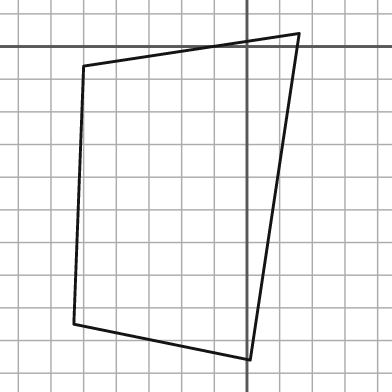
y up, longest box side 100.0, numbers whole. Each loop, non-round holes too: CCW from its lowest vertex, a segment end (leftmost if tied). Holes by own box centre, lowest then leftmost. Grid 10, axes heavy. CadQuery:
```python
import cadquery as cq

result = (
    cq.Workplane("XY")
    .moveTo(1.0, -96.0)
    .lineTo(16.0, 4.0)
    .lineTo(-50.0, -6.0)
    .lineTo(-53.0, -85.0)
    .close()
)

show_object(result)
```